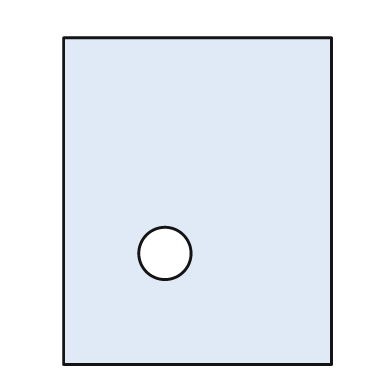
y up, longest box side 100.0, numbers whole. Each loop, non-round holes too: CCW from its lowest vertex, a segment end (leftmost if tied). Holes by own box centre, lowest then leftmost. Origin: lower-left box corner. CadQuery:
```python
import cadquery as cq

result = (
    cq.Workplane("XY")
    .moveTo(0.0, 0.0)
    .lineTo(82.0, 0.0)
    .lineTo(82.0, 100.0)
    .lineTo(0.0, 100.0)
    .close()
    .moveTo(31.0, 34.0)
    .circle(8.0)
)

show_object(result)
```